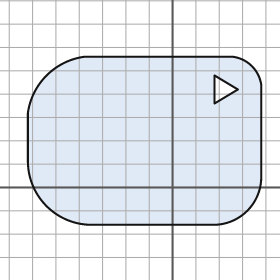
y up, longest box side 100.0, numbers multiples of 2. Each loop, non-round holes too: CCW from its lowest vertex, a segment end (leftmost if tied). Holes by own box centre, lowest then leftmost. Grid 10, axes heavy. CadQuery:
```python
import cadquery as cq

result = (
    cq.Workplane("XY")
    .moveTo(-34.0, -16.0)
    .lineTo(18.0, -16.0)
    .threePointArc((32.0, -10.0), (38.0, 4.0))
    .lineTo(38.0, 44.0)
    .threePointArc((34.0, 52.0), (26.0, 56.0))
    .lineTo(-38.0, 56.0)
    .threePointArc((-54.0, 48.0), (-62.0, 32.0))
    .lineTo(-62.0, 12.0)
    .threePointArc((-54.0, -8.0), (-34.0, -16.0))
    .close()
    .moveTo(18.0, 36.0)
    .lineTo(28.0, 42.0)
    .lineTo(18.0, 48.0)
    .close()
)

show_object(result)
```